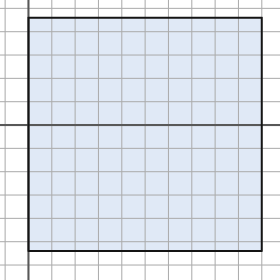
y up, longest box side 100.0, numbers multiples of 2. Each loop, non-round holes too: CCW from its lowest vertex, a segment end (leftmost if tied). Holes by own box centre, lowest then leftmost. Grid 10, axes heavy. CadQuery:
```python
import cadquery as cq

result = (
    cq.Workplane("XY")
    .moveTo(0.0, -54.0)
    .lineTo(100.0, -54.0)
    .lineTo(100.0, 46.0)
    .lineTo(0.0, 46.0)
    .close()
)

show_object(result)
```